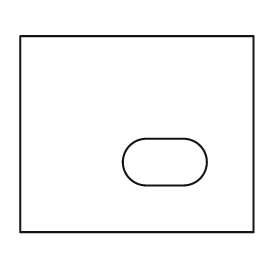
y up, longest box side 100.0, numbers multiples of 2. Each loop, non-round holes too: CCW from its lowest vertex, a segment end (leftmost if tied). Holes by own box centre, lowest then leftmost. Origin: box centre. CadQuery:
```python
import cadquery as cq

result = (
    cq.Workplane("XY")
    .moveTo(-50.0, -42.0)
    .lineTo(50.0, -42.0)
    .lineTo(50.0, 42.0)
    .lineTo(-50.0, 42.0)
    .close()
    .moveTo(4.0, -22.0)
    .lineTo(20.0, -22.0)
    .threePointArc((30.0, -12.0), (20.0, -2.0))
    .lineTo(4.0, -2.0)
    .threePointArc((-6.0, -12.0), (4.0, -22.0))
    .close()
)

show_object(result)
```